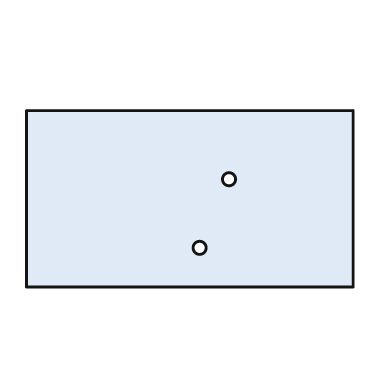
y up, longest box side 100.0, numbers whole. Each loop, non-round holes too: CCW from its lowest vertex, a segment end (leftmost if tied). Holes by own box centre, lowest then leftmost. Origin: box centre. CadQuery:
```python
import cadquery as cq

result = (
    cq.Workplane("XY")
    .moveTo(-50.0, -27.0)
    .lineTo(50.0, -27.0)
    .lineTo(50.0, 27.0)
    .lineTo(-50.0, 27.0)
    .close()
    .moveTo(3.0, -15.0)
    .circle(2.0)
    .moveTo(12.0, 6.0)
    .circle(2.0)
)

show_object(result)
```